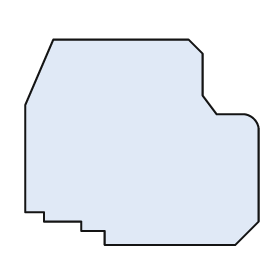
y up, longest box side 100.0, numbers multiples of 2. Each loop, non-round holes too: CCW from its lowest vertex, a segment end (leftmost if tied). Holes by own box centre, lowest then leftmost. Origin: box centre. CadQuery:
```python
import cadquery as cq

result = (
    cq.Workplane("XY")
    .moveTo(-16.0, -44.0)
    .lineTo(40.0, -44.0)
    .lineTo(50.0, -34.0)
    .lineTo(50.0, 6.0)
    .threePointArc((48.0, 10.0), (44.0, 12.0))
    .lineTo(32.0, 12.0)
    .lineTo(26.0, 20.0)
    .lineTo(26.0, 38.0)
    .lineTo(20.0, 44.0)
    .lineTo(-38.0, 44.0)
    .lineTo(-50.0, 16.0)
    .lineTo(-50.0, -30.0)
    .lineTo(-42.0, -30.0)
    .lineTo(-42.0, -34.0)
    .lineTo(-26.0, -34.0)
    .lineTo(-26.0, -38.0)
    .lineTo(-16.0, -38.0)
    .close()
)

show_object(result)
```